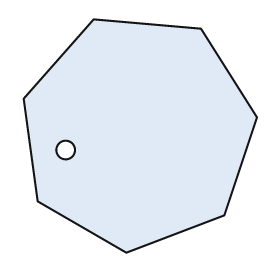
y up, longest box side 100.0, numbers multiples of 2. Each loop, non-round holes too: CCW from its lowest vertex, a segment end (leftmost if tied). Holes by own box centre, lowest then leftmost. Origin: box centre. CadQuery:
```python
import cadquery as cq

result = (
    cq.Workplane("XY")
    .moveTo(-6.0, -50.0)
    .lineTo(36.0, -34.0)
    .lineTo(50.0, 8.0)
    .lineTo(26.0, 46.0)
    .lineTo(-20.0, 50.0)
    .lineTo(-50.0, 16.0)
    .lineTo(-44.0, -28.0)
    .close()
    .moveTo(-32.0, -6.0)
    .circle(4.0)
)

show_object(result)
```